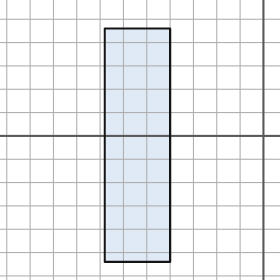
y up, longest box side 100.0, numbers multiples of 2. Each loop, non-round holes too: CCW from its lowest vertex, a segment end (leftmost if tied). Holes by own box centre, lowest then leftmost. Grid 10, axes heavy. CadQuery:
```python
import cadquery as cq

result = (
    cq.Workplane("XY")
    .moveTo(-68.0, -54.0)
    .lineTo(-40.0, -54.0)
    .lineTo(-40.0, 46.0)
    .lineTo(-68.0, 46.0)
    .close()
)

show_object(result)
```